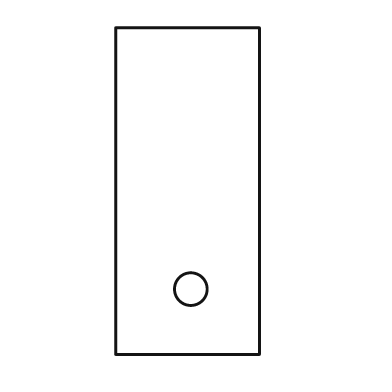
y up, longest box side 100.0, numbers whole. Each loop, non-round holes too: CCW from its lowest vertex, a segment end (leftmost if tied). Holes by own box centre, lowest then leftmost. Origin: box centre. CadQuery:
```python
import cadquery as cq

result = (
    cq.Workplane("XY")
    .moveTo(-22.0, -50.0)
    .lineTo(22.0, -50.0)
    .lineTo(22.0, 50.0)
    .lineTo(-22.0, 50.0)
    .close()
    .moveTo(1.0, -30.0)
    .circle(5.0)
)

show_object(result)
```